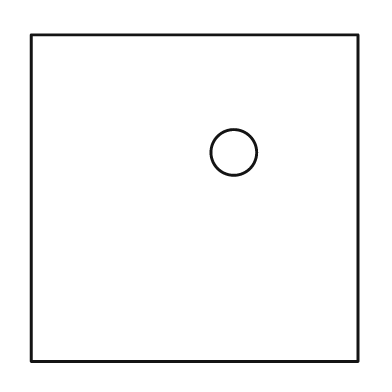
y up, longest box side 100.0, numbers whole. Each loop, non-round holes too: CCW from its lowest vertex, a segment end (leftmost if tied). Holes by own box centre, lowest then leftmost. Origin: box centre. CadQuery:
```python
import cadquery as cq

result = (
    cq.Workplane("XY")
    .moveTo(-50.0, -50.0)
    .lineTo(50.0, -50.0)
    .lineTo(50.0, 50.0)
    .lineTo(-50.0, 50.0)
    .close()
    .moveTo(12.0, 14.0)
    .circle(7.0)
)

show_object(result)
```